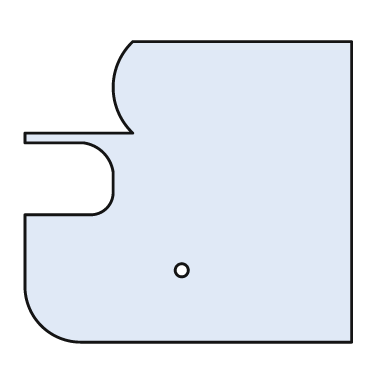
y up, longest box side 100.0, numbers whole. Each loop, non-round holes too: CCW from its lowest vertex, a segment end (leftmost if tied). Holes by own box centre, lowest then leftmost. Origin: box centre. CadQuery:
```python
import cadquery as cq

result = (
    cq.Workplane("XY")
    .moveTo(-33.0, -46.0)
    .lineTo(50.0, -46.0)
    .lineTo(50.0, 46.0)
    .lineTo(-17.0, 46.0)
    .threePointArc((-23.0, 32.0), (-17.0, 18.0))
    .lineTo(-50.0, 18.0)
    .lineTo(-50.0, 15.0)
    .lineTo(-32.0, 15.0)
    .threePointArc((-26.0, 12.0), (-23.0, 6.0))
    .lineTo(-23.0, 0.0)
    .threePointArc((-25.0, -5.0), (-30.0, -7.0))
    .lineTo(-50.0, -7.0)
    .lineTo(-50.0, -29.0)
    .threePointArc((-45.0, -41.0), (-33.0, -46.0))
    .close()
    .moveTo(-2.0, -24.0)
    .circle(2.0)
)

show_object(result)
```